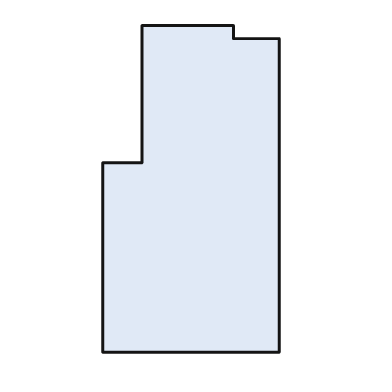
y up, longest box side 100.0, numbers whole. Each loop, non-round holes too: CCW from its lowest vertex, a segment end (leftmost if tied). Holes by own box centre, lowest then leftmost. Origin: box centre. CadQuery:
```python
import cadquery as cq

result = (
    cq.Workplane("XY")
    .moveTo(-27.0, -50.0)
    .lineTo(27.0, -50.0)
    .lineTo(27.0, 46.0)
    .lineTo(13.0, 46.0)
    .lineTo(13.0, 50.0)
    .lineTo(-15.0, 50.0)
    .lineTo(-15.0, 8.0)
    .lineTo(-27.0, 8.0)
    .close()
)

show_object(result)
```